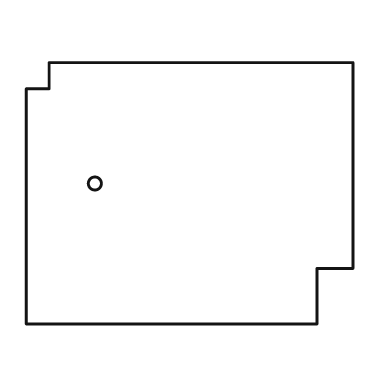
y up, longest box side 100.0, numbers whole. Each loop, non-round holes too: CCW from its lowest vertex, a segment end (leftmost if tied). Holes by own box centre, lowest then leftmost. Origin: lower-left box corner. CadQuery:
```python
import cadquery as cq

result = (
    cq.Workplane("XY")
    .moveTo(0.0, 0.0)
    .lineTo(89.0, 0.0)
    .lineTo(89.0, 17.0)
    .lineTo(100.0, 17.0)
    .lineTo(100.0, 80.0)
    .lineTo(7.0, 80.0)
    .lineTo(7.0, 72.0)
    .lineTo(0.0, 72.0)
    .close()
    .moveTo(21.0, 43.0)
    .circle(2.0)
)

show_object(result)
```